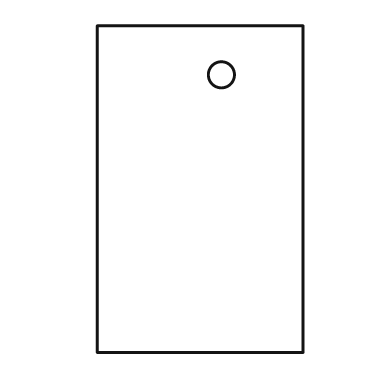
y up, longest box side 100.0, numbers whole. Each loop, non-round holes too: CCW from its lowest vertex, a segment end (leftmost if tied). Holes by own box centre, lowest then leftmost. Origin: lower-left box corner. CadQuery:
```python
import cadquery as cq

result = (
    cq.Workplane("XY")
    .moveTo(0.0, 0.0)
    .lineTo(63.0, 0.0)
    .lineTo(63.0, 100.0)
    .lineTo(0.0, 100.0)
    .close()
    .moveTo(38.0, 85.0)
    .circle(4.0)
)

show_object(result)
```